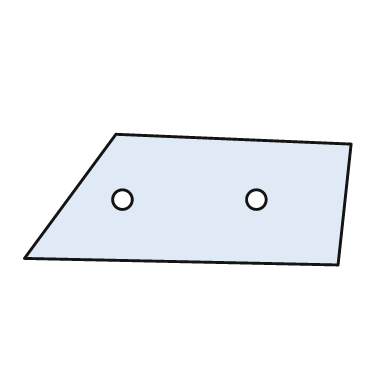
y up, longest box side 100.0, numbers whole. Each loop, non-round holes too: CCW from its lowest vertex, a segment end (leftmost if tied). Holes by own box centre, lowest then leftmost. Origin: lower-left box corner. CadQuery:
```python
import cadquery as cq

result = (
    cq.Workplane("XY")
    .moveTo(96.0, 0.0)
    .lineTo(100.0, 37.0)
    .lineTo(28.0, 40.0)
    .lineTo(0.0, 2.0)
    .close()
    .moveTo(30.0, 20.0)
    .circle(3.0)
    .moveTo(71.0, 20.0)
    .circle(3.0)
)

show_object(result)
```